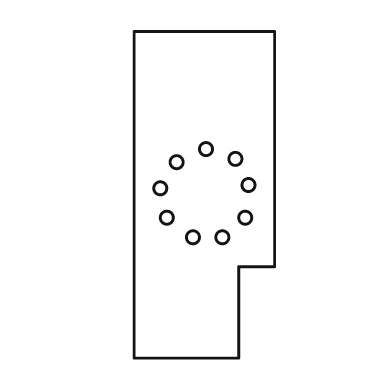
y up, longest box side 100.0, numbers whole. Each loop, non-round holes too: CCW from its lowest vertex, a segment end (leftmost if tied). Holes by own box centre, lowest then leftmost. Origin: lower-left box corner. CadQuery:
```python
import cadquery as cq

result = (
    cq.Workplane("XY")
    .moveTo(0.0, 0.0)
    .lineTo(32.0, 0.0)
    .lineTo(32.0, 28.0)
    .lineTo(43.0, 28.0)
    .lineTo(43.0, 100.0)
    .lineTo(0.0, 100.0)
    .close()
    .moveTo(18.0, 37.0)
    .circle(2.0)
    .moveTo(27.0, 37.0)
    .circle(2.0)
    .moveTo(10.0, 43.0)
    .circle(2.0)
    .moveTo(34.0, 43.0)
    .circle(2.0)
    .moveTo(8.0, 52.0)
    .circle(2.0)
    .moveTo(35.0, 53.0)
    .circle(2.0)
    .moveTo(13.0, 60.0)
    .circle(2.0)
    .moveTo(31.0, 61.0)
    .circle(2.0)
    .moveTo(22.0, 64.0)
    .circle(2.0)
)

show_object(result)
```